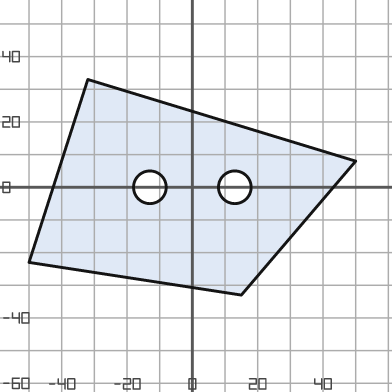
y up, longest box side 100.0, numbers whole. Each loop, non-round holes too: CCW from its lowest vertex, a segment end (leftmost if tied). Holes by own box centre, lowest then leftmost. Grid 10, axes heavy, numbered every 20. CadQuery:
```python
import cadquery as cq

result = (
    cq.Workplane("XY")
    .moveTo(15.0, -33.0)
    .lineTo(50.0, 8.0)
    .lineTo(-32.0, 33.0)
    .lineTo(-50.0, -23.0)
    .close()
    .moveTo(-13.0, 0.0)
    .circle(5.0)
    .moveTo(13.0, 0.0)
    .circle(5.0)
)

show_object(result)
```